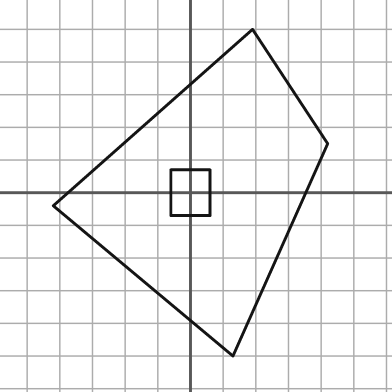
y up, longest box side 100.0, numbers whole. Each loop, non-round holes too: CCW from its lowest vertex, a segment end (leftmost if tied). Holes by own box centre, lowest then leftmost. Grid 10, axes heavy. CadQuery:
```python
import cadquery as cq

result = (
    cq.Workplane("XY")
    .moveTo(13.0, -50.0)
    .lineTo(42.0, 15.0)
    .lineTo(19.0, 50.0)
    .lineTo(-42.0, -4.0)
    .close()
    .moveTo(-6.0, -7.0)
    .lineTo(6.0, -7.0)
    .lineTo(6.0, 7.0)
    .lineTo(-6.0, 7.0)
    .close()
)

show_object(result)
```